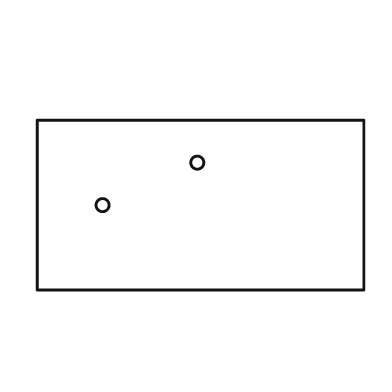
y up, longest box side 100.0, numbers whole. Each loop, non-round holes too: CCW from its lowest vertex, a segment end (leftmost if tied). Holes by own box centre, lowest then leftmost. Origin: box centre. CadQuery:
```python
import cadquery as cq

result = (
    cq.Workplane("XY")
    .moveTo(-50.0, -26.0)
    .lineTo(50.0, -26.0)
    .lineTo(50.0, 26.0)
    .lineTo(-50.0, 26.0)
    .close()
    .moveTo(-30.0, 0.0)
    .circle(2.0)
    .moveTo(-1.0, 13.0)
    .circle(2.0)
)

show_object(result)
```